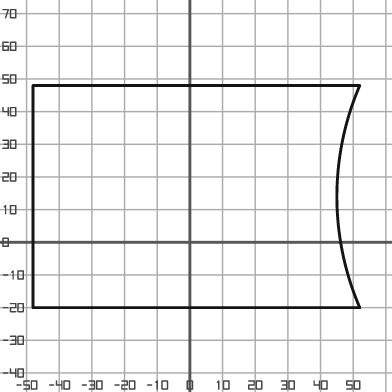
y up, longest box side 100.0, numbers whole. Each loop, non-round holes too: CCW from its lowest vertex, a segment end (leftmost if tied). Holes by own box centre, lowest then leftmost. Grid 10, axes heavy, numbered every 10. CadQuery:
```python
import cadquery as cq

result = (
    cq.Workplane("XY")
    .moveTo(-48.0, -20.0)
    .lineTo(52.0, -20.0)
    .threePointArc((45.0, 14.0), (52.0, 48.0))
    .lineTo(-48.0, 48.0)
    .close()
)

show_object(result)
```